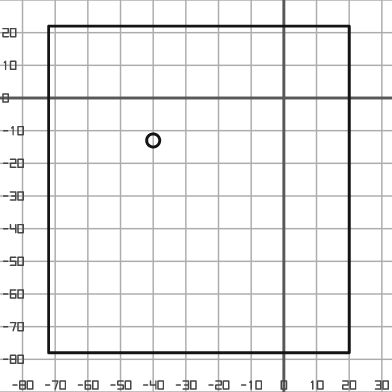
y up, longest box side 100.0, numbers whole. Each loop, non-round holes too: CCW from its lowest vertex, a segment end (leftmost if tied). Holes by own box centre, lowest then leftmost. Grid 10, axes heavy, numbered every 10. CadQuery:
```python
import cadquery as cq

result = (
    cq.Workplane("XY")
    .moveTo(-72.0, -78.0)
    .lineTo(20.0, -78.0)
    .lineTo(20.0, 22.0)
    .lineTo(-72.0, 22.0)
    .close()
    .moveTo(-40.0, -13.0)
    .circle(2.0)
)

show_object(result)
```